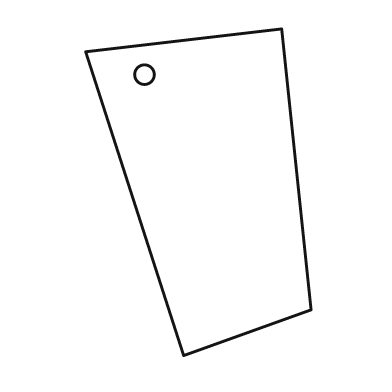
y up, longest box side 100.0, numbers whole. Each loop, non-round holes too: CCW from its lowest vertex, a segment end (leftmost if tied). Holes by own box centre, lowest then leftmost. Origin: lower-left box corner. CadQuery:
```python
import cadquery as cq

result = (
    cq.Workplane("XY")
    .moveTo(30.0, 0.0)
    .lineTo(69.0, 14.0)
    .lineTo(60.0, 100.0)
    .lineTo(0.0, 93.0)
    .close()
    .moveTo(18.0, 86.0)
    .circle(3.0)
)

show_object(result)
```